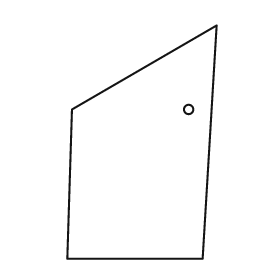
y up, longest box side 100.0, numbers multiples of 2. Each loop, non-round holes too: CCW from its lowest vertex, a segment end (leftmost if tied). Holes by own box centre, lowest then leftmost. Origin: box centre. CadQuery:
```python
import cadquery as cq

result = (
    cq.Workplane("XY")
    .moveTo(-32.0, -50.0)
    .lineTo(26.0, -50.0)
    .lineTo(32.0, 50.0)
    .lineTo(-30.0, 14.0)
    .close()
    .moveTo(20.0, 14.0)
    .circle(2.0)
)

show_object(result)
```